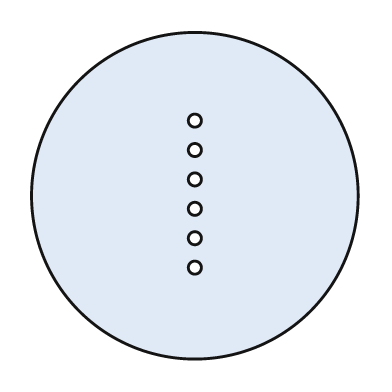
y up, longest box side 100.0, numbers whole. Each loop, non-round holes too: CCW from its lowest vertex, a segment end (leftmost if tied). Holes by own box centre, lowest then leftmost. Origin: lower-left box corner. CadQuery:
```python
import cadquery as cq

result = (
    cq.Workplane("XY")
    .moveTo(50.0, 50.0)
    .circle(50.0)
    .moveTo(50.0, 28.0)
    .circle(2.0)
    .moveTo(50.0, 37.0)
    .circle(2.0)
    .moveTo(50.0, 46.0)
    .circle(2.0)
    .moveTo(50.0, 55.0)
    .circle(2.0)
    .moveTo(50.0, 64.0)
    .circle(2.0)
    .moveTo(50.0, 73.0)
    .circle(2.0)
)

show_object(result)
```